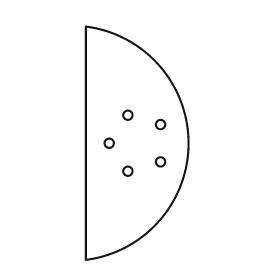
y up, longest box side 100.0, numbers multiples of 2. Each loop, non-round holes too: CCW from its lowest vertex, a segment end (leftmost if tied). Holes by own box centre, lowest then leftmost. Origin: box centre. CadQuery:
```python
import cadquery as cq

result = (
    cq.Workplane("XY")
    .moveTo(-22.0, -50.0)
    .threePointArc((22.0, 0.0), (-22.0, 50.0))
    .close()
    .moveTo(-4.0, -12.0)
    .circle(2.0)
    .moveTo(10.0, -8.0)
    .circle(2.0)
    .moveTo(-12.0, 0.0)
    .circle(2.0)
    .moveTo(10.0, 8.0)
    .circle(2.0)
    .moveTo(-4.0, 12.0)
    .circle(2.0)
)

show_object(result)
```